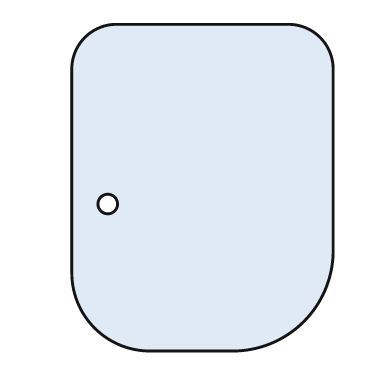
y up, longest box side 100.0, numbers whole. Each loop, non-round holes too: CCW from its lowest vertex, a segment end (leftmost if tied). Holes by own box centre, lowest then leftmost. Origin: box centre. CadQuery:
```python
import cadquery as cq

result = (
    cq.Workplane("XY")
    .moveTo(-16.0, -50.0)
    .lineTo(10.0, -50.0)
    .threePointArc((31.0, -41.0), (40.0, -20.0))
    .lineTo(40.0, 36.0)
    .threePointArc((36.0, 46.0), (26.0, 50.0))
    .lineTo(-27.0, 50.0)
    .threePointArc((-36.0, 46.0), (-40.0, 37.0))
    .lineTo(-40.0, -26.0)
    .threePointArc((-33.0, -43.0), (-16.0, -50.0))
    .close()
    .moveTo(-29.0, -5.0)
    .circle(3.0)
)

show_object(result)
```